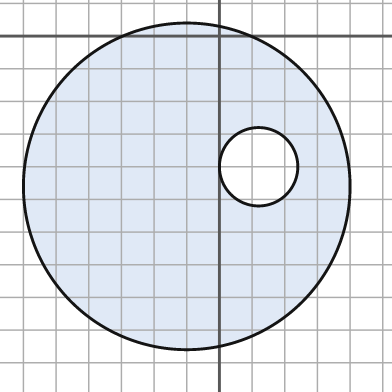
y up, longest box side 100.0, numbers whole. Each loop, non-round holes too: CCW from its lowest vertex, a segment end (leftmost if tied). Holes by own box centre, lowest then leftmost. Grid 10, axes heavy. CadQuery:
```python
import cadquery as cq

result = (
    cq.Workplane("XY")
    .moveTo(-10.0, -46.0)
    .circle(50.0)
    .moveTo(12.0, -40.0)
    .circle(12.0)
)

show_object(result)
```